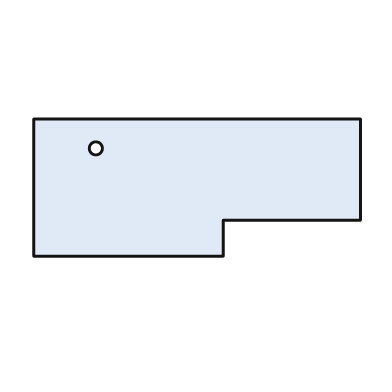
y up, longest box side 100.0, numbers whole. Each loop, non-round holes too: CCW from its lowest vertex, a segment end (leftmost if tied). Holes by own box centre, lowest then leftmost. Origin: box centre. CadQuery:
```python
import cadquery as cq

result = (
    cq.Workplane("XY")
    .moveTo(-50.0, -21.0)
    .lineTo(8.0, -21.0)
    .lineTo(8.0, -10.0)
    .lineTo(50.0, -10.0)
    .lineTo(50.0, 21.0)
    .lineTo(-50.0, 21.0)
    .close()
    .moveTo(-31.0, 12.0)
    .circle(2.0)
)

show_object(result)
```